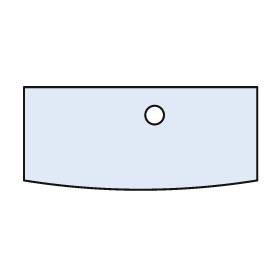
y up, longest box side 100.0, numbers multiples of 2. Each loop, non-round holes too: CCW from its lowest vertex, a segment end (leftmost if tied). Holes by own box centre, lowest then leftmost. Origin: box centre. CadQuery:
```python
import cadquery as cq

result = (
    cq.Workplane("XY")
    .moveTo(-50.0, -18.0)
    .threePointArc((0.0, -22.0), (50.0, -18.0))
    .lineTo(50.0, 22.0)
    .lineTo(-50.0, 22.0)
    .close()
    .moveTo(6.0, 10.0)
    .circle(4.0)
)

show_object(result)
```